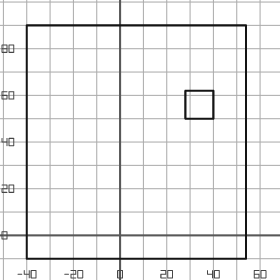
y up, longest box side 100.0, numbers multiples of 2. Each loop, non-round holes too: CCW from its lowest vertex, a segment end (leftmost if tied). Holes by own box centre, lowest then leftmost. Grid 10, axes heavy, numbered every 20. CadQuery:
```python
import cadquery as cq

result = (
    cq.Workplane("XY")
    .moveTo(-40.0, -10.0)
    .lineTo(54.0, -10.0)
    .lineTo(54.0, 90.0)
    .lineTo(-40.0, 90.0)
    .close()
    .moveTo(28.0, 50.0)
    .lineTo(40.0, 50.0)
    .lineTo(40.0, 62.0)
    .lineTo(28.0, 62.0)
    .close()
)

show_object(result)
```